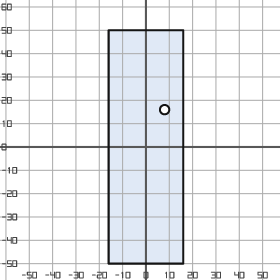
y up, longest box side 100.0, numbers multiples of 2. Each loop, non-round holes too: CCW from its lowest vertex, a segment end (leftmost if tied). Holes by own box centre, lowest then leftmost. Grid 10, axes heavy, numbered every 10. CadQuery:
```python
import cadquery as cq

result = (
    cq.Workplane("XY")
    .moveTo(-16.0, -50.0)
    .lineTo(16.0, -50.0)
    .lineTo(16.0, 50.0)
    .lineTo(-16.0, 50.0)
    .close()
    .moveTo(8.0, 16.0)
    .circle(2.0)
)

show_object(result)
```